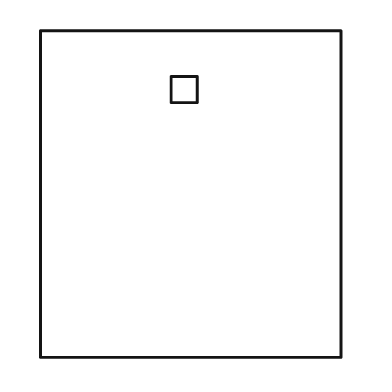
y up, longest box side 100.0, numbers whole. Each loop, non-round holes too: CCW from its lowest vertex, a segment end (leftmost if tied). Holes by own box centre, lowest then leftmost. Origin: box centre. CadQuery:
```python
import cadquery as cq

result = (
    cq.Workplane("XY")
    .moveTo(-46.0, -50.0)
    .lineTo(46.0, -50.0)
    .lineTo(46.0, 50.0)
    .lineTo(-46.0, 50.0)
    .close()
    .moveTo(-6.0, 28.0)
    .lineTo(2.0, 28.0)
    .lineTo(2.0, 36.0)
    .lineTo(-6.0, 36.0)
    .close()
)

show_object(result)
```